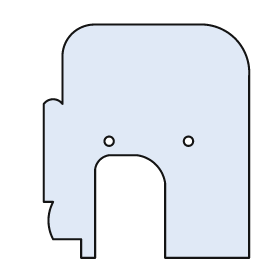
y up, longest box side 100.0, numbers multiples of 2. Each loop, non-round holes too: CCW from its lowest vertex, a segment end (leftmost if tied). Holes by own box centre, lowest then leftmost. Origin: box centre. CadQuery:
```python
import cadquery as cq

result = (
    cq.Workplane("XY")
    .moveTo(-28.0, -50.0)
    .lineTo(-22.0, -50.0)
    .lineTo(-22.0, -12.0)
    .threePointArc((-20.0, -8.0), (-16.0, -6.0))
    .lineTo(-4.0, -6.0)
    .threePointArc((4.0, -10.0), (8.0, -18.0))
    .lineTo(8.0, -50.0)
    .lineTo(44.0, -50.0)
    .lineTo(44.0, 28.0)
    .threePointArc((38.0, 44.0), (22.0, 50.0))
    .lineTo(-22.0, 50.0)
    .threePointArc((-32.0, 46.0), (-36.0, 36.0))
    .lineTo(-36.0, 16.0)
    .threePointArc((-40.0, 18.0), (-44.0, 16.0))
    .lineTo(-44.0, -26.0)
    .lineTo(-40.0, -26.0)
    .threePointArc((-42.0, -34.0), (-40.0, -42.0))
    .lineTo(-28.0, -42.0)
    .close()
    .moveTo(-16.0, 0.0)
    .circle(2.0)
    .moveTo(18.0, 0.0)
    .circle(2.0)
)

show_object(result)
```